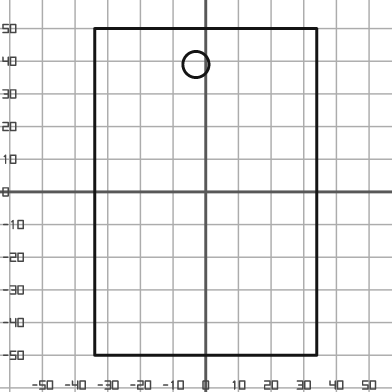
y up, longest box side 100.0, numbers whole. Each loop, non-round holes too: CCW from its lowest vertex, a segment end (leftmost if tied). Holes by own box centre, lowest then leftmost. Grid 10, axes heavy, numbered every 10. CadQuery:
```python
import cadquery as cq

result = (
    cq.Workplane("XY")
    .moveTo(-34.0, -50.0)
    .lineTo(34.0, -50.0)
    .lineTo(34.0, 50.0)
    .lineTo(-34.0, 50.0)
    .close()
    .moveTo(-3.0, 39.0)
    .circle(4.0)
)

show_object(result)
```